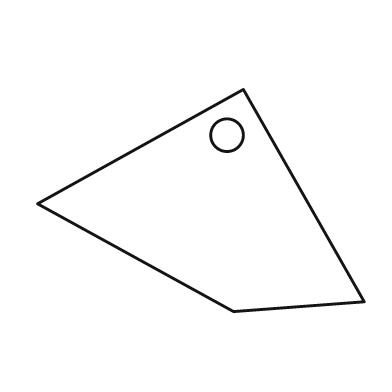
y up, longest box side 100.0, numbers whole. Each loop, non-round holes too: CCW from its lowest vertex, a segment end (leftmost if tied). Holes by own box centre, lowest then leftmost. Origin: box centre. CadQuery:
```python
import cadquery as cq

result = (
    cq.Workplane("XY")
    .moveTo(10.0, -34.0)
    .lineTo(50.0, -31.0)
    .lineTo(13.0, 34.0)
    .lineTo(-50.0, -1.0)
    .close()
    .moveTo(8.0, 20.0)
    .circle(5.0)
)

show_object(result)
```